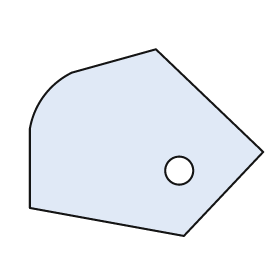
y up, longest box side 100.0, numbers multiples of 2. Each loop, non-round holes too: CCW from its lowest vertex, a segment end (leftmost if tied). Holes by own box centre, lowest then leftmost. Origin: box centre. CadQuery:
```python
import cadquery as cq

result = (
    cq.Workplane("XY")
    .moveTo(16.0, -40.0)
    .lineTo(50.0, -4.0)
    .lineTo(4.0, 40.0)
    .lineTo(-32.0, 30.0)
    .threePointArc((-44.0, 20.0), (-50.0, 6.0))
    .lineTo(-50.0, -28.0)
    .close()
    .moveTo(14.0, -12.0)
    .circle(6.0)
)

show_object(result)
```